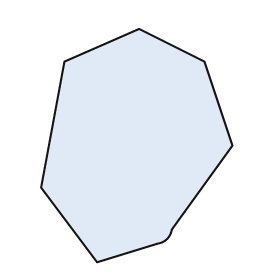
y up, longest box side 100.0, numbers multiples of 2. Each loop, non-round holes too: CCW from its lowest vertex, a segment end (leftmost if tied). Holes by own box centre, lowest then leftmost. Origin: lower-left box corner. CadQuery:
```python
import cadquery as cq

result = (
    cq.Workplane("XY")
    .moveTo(24.0, 0.0)
    .lineTo(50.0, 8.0)
    .threePointArc((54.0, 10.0), (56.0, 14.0))
    .lineTo(82.0, 50.0)
    .lineTo(70.0, 86.0)
    .lineTo(42.0, 100.0)
    .lineTo(10.0, 86.0)
    .lineTo(0.0, 32.0)
    .close()
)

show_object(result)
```